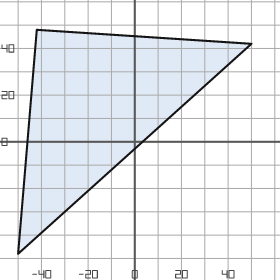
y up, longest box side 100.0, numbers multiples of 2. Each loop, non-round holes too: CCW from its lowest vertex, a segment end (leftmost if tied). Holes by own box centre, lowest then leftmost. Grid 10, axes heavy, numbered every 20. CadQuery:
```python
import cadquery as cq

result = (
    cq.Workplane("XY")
    .moveTo(-50.0, -48.0)
    .lineTo(50.0, 42.0)
    .lineTo(-42.0, 48.0)
    .close()
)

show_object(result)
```